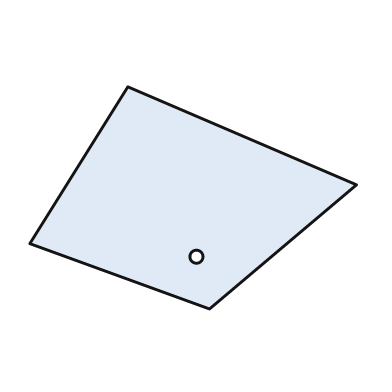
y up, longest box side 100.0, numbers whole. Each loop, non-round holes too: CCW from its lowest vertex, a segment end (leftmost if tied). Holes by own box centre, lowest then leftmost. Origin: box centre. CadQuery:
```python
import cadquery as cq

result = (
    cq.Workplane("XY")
    .moveTo(5.0, -34.0)
    .lineTo(50.0, 4.0)
    .lineTo(-20.0, 34.0)
    .lineTo(-50.0, -14.0)
    .close()
    .moveTo(1.0, -18.0)
    .circle(2.0)
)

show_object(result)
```